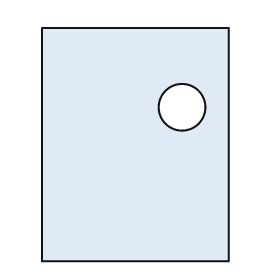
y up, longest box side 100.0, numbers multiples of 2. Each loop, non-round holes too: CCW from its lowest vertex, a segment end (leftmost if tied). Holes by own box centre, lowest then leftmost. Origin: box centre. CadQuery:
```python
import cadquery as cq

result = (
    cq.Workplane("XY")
    .moveTo(-40.0, -50.0)
    .lineTo(40.0, -50.0)
    .lineTo(40.0, 50.0)
    .lineTo(-40.0, 50.0)
    .close()
    .moveTo(20.0, 16.0)
    .circle(10.0)
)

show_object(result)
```